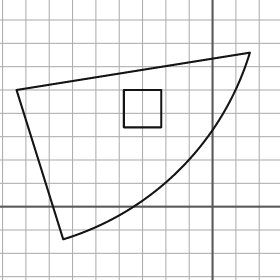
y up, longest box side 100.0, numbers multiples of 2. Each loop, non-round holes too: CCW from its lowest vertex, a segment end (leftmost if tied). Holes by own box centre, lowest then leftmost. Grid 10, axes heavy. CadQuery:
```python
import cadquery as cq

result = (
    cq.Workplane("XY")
    .moveTo(-64.0, -14.0)
    .threePointArc((-14.0, 16.0), (16.0, 66.0))
    .lineTo(-84.0, 50.0)
    .close()
    .moveTo(-38.0, 34.0)
    .lineTo(-22.0, 34.0)
    .lineTo(-22.0, 50.0)
    .lineTo(-38.0, 50.0)
    .close()
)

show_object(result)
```